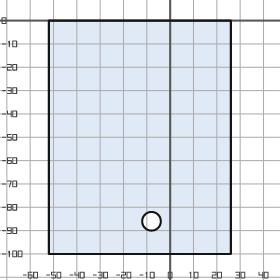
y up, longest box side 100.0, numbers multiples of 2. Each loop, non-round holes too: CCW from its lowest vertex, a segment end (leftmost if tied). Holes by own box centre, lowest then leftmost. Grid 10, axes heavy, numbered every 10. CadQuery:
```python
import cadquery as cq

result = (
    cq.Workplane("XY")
    .moveTo(-52.0, -100.0)
    .lineTo(26.0, -100.0)
    .lineTo(26.0, 0.0)
    .lineTo(-52.0, 0.0)
    .close()
    .moveTo(-8.0, -86.0)
    .circle(4.0)
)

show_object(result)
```